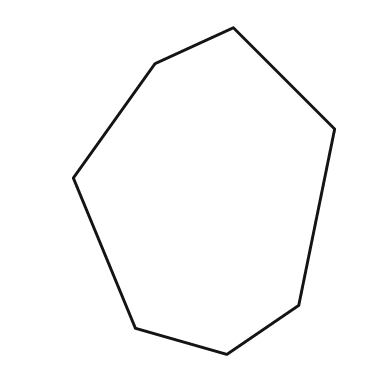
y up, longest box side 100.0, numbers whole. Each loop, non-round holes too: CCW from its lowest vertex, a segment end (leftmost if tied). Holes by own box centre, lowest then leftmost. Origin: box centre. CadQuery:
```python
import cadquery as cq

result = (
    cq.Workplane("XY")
    .moveTo(7.0, -50.0)
    .lineTo(29.0, -35.0)
    .lineTo(40.0, 19.0)
    .lineTo(9.0, 50.0)
    .lineTo(-15.0, 39.0)
    .lineTo(-40.0, 4.0)
    .lineTo(-21.0, -42.0)
    .close()
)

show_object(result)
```